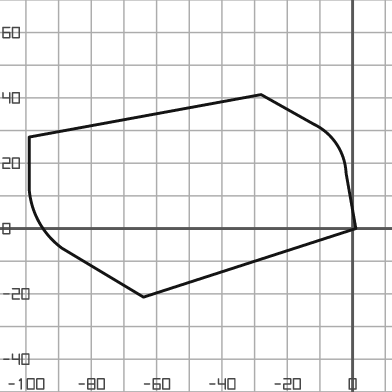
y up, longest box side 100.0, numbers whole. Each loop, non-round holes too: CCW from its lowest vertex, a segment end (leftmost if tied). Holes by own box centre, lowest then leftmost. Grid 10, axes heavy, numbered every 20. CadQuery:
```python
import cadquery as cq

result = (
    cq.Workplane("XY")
    .moveTo(-64.0, -21.0)
    .lineTo(1.0, 0.0)
    .lineTo(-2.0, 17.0)
    .threePointArc((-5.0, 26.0), (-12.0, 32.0))
    .lineTo(-28.0, 41.0)
    .lineTo(-99.0, 28.0)
    .lineTo(-99.0, 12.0)
    .threePointArc((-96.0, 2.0), (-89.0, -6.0))
    .close()
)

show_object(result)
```